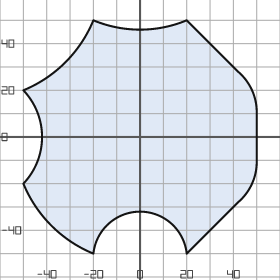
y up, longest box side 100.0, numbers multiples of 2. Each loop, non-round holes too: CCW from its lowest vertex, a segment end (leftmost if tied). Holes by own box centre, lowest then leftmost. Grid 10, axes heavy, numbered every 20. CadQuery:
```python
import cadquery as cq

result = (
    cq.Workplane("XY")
    .moveTo(-20.0, -50.0)
    .threePointArc((0.0, -32.0), (20.0, -50.0))
    .lineTo(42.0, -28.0)
    .threePointArc((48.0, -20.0), (50.0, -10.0))
    .lineTo(50.0, 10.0)
    .threePointArc((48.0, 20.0), (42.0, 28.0))
    .lineTo(20.0, 50.0)
    .threePointArc((0.0, 46.0), (-20.0, 50.0))
    .threePointArc((-32.0, 32.0), (-50.0, 20.0))
    .threePointArc((-42.0, 0.0), (-50.0, -20.0))
    .threePointArc((-38.0, -38.0), (-20.0, -50.0))
    .close()
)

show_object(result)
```